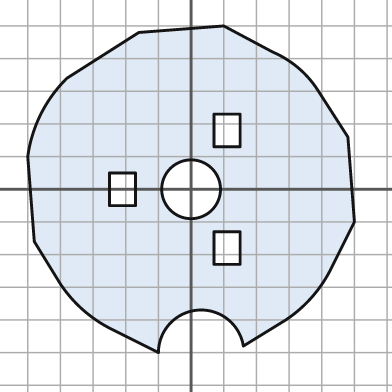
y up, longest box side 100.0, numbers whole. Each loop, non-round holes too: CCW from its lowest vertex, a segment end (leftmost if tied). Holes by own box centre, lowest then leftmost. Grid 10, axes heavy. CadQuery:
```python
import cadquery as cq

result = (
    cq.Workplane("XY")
    .moveTo(-10.0, -50.0)
    .threePointArc((2.0, -37.0), (16.0, -48.0))
    .lineTo(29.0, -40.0)
    .threePointArc((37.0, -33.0), (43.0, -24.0))
    .lineTo(50.0, -10.0)
    .lineTo(48.0, 16.0)
    .lineTo(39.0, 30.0)
    .threePointArc((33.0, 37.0), (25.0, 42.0))
    .lineTo(10.0, 50.0)
    .lineTo(-16.0, 48.0)
    .lineTo(-38.0, 34.0)
    .threePointArc((-46.0, 23.0), (-50.0, 10.0))
    .lineTo(-48.0, -16.0)
    .lineTo(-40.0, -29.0)
    .threePointArc((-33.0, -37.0), (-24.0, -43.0))
    .close()
    .moveTo(7.0, -23.0)
    .lineTo(15.0, -23.0)
    .lineTo(15.0, -13.0)
    .lineTo(7.0, -13.0)
    .close()
    .moveTo(-25.0, -5.0)
    .lineTo(-17.0, -5.0)
    .lineTo(-17.0, 5.0)
    .lineTo(-25.0, 5.0)
    .close()
    .moveTo(0.0, 0.0)
    .circle(9.0)
    .moveTo(7.0, 13.0)
    .lineTo(15.0, 13.0)
    .lineTo(15.0, 23.0)
    .lineTo(7.0, 23.0)
    .close()
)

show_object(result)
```